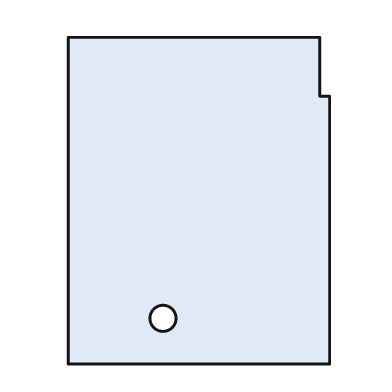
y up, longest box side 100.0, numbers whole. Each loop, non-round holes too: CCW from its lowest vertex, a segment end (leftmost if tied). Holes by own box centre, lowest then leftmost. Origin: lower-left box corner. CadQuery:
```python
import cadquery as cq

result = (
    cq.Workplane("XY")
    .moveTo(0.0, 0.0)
    .lineTo(80.0, 0.0)
    .lineTo(80.0, 82.0)
    .lineTo(77.0, 82.0)
    .lineTo(77.0, 100.0)
    .lineTo(0.0, 100.0)
    .close()
    .moveTo(29.0, 14.0)
    .circle(4.0)
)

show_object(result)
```